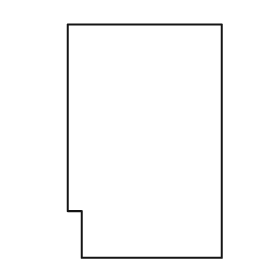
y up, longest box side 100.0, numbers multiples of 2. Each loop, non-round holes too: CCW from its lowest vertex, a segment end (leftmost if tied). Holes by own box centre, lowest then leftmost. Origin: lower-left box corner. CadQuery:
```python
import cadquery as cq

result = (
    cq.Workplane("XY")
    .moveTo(6.0, 0.0)
    .lineTo(66.0, 0.0)
    .lineTo(66.0, 100.0)
    .lineTo(0.0, 100.0)
    .lineTo(0.0, 20.0)
    .lineTo(6.0, 20.0)
    .close()
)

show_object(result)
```